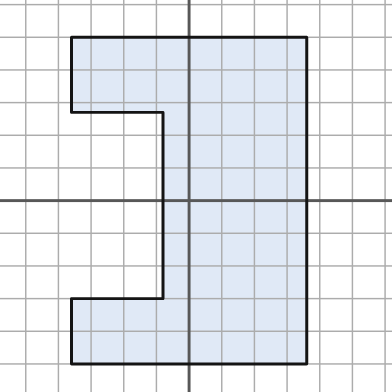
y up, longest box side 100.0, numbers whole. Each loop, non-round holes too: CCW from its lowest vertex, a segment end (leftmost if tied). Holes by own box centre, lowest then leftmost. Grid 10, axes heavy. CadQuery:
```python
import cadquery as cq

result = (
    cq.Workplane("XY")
    .moveTo(-36.0, -50.0)
    .lineTo(36.0, -50.0)
    .lineTo(36.0, 50.0)
    .lineTo(-36.0, 50.0)
    .lineTo(-36.0, 27.0)
    .lineTo(-8.0, 27.0)
    .lineTo(-8.0, -30.0)
    .lineTo(-36.0, -30.0)
    .close()
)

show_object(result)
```